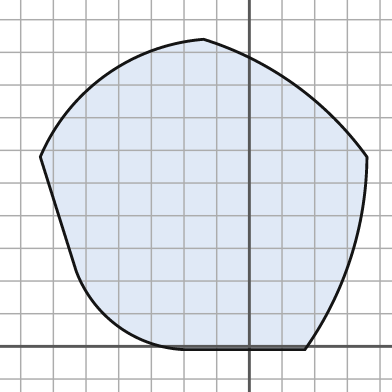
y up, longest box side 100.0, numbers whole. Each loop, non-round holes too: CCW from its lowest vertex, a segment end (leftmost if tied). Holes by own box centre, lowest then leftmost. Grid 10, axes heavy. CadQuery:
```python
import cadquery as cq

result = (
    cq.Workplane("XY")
    .moveTo(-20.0, -1.0)
    .lineTo(17.0, -1.0)
    .threePointArc((31.0, 27.0), (36.0, 58.0))
    .threePointArc((14.0, 80.0), (-14.0, 94.0))
    .threePointArc((-44.0, 83.0), (-64.0, 58.0))
    .lineTo(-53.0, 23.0)
    .threePointArc((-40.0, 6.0), (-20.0, -1.0))
    .close()
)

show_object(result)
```